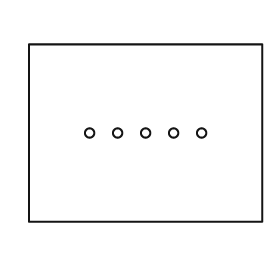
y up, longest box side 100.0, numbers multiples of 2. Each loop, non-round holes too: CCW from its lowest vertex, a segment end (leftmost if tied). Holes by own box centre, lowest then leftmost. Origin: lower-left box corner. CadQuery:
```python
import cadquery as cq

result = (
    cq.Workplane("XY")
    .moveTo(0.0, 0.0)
    .lineTo(100.0, 0.0)
    .lineTo(100.0, 76.0)
    .lineTo(0.0, 76.0)
    .close()
    .moveTo(26.0, 38.0)
    .circle(2.0)
    .moveTo(38.0, 38.0)
    .circle(2.0)
    .moveTo(50.0, 38.0)
    .circle(2.0)
    .moveTo(62.0, 38.0)
    .circle(2.0)
    .moveTo(74.0, 38.0)
    .circle(2.0)
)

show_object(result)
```